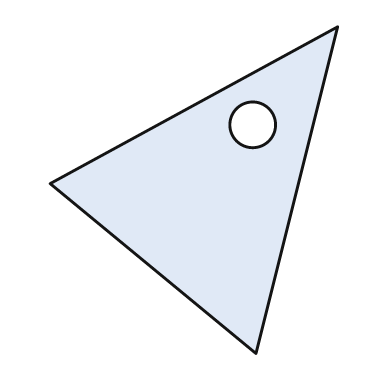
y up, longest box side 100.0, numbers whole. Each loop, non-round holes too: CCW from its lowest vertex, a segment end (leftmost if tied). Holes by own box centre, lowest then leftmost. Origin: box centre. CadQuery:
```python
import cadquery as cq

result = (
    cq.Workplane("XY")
    .moveTo(19.0, -50.0)
    .lineTo(44.0, 50.0)
    .lineTo(-44.0, 2.0)
    .close()
    .moveTo(18.0, 20.0)
    .circle(7.0)
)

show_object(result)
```